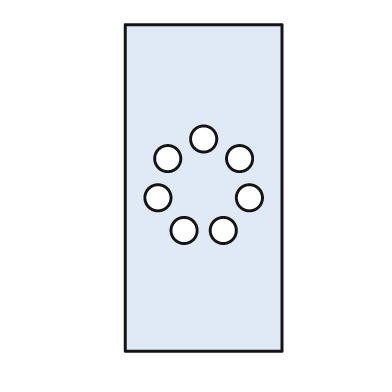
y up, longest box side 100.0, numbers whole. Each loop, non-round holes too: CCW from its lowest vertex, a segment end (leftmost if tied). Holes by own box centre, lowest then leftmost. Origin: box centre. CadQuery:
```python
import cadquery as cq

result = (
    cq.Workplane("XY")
    .moveTo(-24.0, -50.0)
    .lineTo(24.0, -50.0)
    .lineTo(24.0, 50.0)
    .lineTo(-24.0, 50.0)
    .close()
    .moveTo(-6.0, -13.0)
    .circle(4.0)
    .moveTo(6.0, -13.0)
    .circle(4.0)
    .moveTo(-14.0, -3.0)
    .circle(4.0)
    .moveTo(14.0, -3.0)
    .circle(4.0)
    .moveTo(-11.0, 9.0)
    .circle(4.0)
    .moveTo(11.0, 9.0)
    .circle(4.0)
    .moveTo(0.0, 15.0)
    .circle(4.0)
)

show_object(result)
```